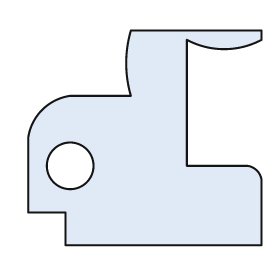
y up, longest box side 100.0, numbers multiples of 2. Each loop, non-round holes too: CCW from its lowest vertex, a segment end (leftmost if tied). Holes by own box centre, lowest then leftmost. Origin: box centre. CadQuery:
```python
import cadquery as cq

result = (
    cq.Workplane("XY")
    .moveTo(-34.0, -46.0)
    .lineTo(50.0, -46.0)
    .lineTo(50.0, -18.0)
    .threePointArc((48.0, -14.0), (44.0, -12.0))
    .lineTo(18.0, -12.0)
    .lineTo(18.0, 42.0)
    .threePointArc((34.0, 38.0), (50.0, 42.0))
    .lineTo(50.0, 46.0)
    .lineTo(-6.0, 46.0)
    .threePointArc((-8.0, 32.0), (-6.0, 18.0))
    .lineTo(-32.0, 18.0)
    .threePointArc((-44.0, 12.0), (-50.0, 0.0))
    .lineTo(-50.0, -32.0)
    .lineTo(-34.0, -32.0)
    .close()
    .moveTo(-32.0, -12.0)
    .circle(10.0)
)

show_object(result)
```